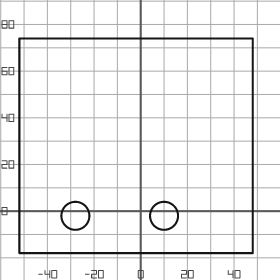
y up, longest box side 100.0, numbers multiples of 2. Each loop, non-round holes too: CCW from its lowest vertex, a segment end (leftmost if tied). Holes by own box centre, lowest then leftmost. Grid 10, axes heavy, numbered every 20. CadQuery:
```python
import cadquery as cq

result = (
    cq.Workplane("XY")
    .moveTo(-52.0, -18.0)
    .lineTo(48.0, -18.0)
    .lineTo(48.0, 74.0)
    .lineTo(-52.0, 74.0)
    .close()
    .moveTo(-28.0, -2.0)
    .circle(6.0)
    .moveTo(10.0, -2.0)
    .circle(6.0)
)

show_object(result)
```